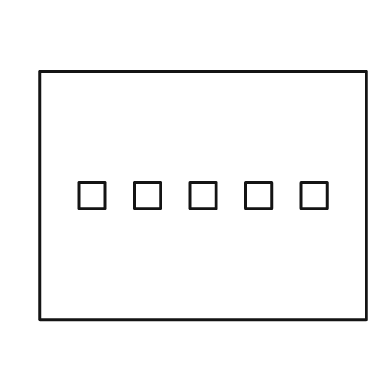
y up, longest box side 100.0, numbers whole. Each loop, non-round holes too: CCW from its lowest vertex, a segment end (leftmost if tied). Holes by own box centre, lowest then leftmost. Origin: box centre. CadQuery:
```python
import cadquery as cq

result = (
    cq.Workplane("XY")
    .moveTo(-50.0, -38.0)
    .lineTo(50.0, -38.0)
    .lineTo(50.0, 38.0)
    .lineTo(-50.0, 38.0)
    .close()
    .moveTo(-38.0, -4.0)
    .lineTo(-30.0, -4.0)
    .lineTo(-30.0, 4.0)
    .lineTo(-38.0, 4.0)
    .close()
    .moveTo(-21.0, -4.0)
    .lineTo(-13.0, -4.0)
    .lineTo(-13.0, 4.0)
    .lineTo(-21.0, 4.0)
    .close()
    .moveTo(-4.0, -4.0)
    .lineTo(4.0, -4.0)
    .lineTo(4.0, 4.0)
    .lineTo(-4.0, 4.0)
    .close()
    .moveTo(13.0, -4.0)
    .lineTo(21.0, -4.0)
    .lineTo(21.0, 4.0)
    .lineTo(13.0, 4.0)
    .close()
    .moveTo(30.0, -4.0)
    .lineTo(38.0, -4.0)
    .lineTo(38.0, 4.0)
    .lineTo(30.0, 4.0)
    .close()
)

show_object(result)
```